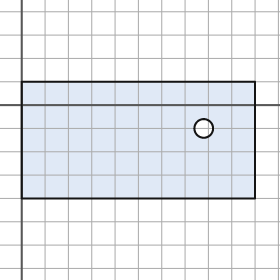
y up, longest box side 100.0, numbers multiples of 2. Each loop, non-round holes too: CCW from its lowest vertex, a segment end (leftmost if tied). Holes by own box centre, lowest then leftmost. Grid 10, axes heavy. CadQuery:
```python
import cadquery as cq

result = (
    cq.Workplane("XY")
    .moveTo(0.0, -40.0)
    .lineTo(100.0, -40.0)
    .lineTo(100.0, 10.0)
    .lineTo(0.0, 10.0)
    .close()
    .moveTo(78.0, -10.0)
    .circle(4.0)
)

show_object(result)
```